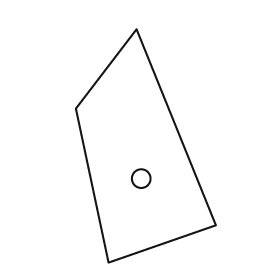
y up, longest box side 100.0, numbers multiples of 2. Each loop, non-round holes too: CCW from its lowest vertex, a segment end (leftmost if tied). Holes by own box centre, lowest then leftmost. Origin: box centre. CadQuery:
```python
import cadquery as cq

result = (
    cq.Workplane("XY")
    .moveTo(-16.0, -50.0)
    .lineTo(30.0, -34.0)
    .lineTo(-4.0, 50.0)
    .lineTo(-30.0, 16.0)
    .close()
    .moveTo(-2.0, -14.0)
    .circle(4.0)
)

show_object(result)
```